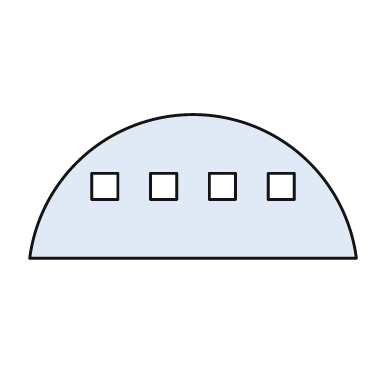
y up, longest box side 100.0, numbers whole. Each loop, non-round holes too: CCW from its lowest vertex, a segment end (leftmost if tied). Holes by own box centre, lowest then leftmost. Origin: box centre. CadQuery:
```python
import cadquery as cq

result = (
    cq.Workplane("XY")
    .moveTo(-50.0, -22.0)
    .lineTo(50.0, -22.0)
    .threePointArc((0.0, 22.0), (-50.0, -22.0))
    .close()
    .moveTo(-31.0, -4.0)
    .lineTo(-23.0, -4.0)
    .lineTo(-23.0, 4.0)
    .lineTo(-31.0, 4.0)
    .close()
    .moveTo(-13.0, -4.0)
    .lineTo(-5.0, -4.0)
    .lineTo(-5.0, 4.0)
    .lineTo(-13.0, 4.0)
    .close()
    .moveTo(5.0, -4.0)
    .lineTo(13.0, -4.0)
    .lineTo(13.0, 4.0)
    .lineTo(5.0, 4.0)
    .close()
    .moveTo(23.0, -4.0)
    .lineTo(31.0, -4.0)
    .lineTo(31.0, 4.0)
    .lineTo(23.0, 4.0)
    .close()
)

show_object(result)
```